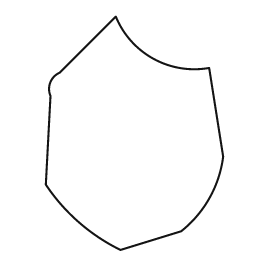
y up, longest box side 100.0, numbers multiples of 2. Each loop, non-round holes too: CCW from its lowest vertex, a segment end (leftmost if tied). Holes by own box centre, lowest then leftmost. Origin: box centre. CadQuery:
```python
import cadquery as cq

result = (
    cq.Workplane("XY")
    .moveTo(-6.0, -50.0)
    .lineTo(20.0, -42.0)
    .threePointArc((32.0, -28.0), (38.0, -10.0))
    .lineTo(32.0, 28.0)
    .threePointArc((8.0, 32.0), (-8.0, 50.0))
    .lineTo(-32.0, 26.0)
    .threePointArc((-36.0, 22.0), (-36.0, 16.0))
    .lineTo(-38.0, -22.0)
    .threePointArc((-24.0, -38.0), (-6.0, -50.0))
    .close()
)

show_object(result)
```